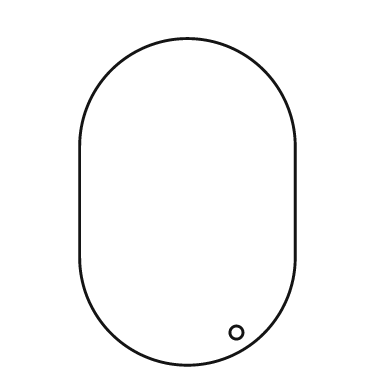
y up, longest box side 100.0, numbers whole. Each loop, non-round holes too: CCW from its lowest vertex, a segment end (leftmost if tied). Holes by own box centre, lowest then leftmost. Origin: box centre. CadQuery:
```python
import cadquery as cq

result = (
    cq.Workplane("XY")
    .moveTo(-33.0, -17.0)
    .threePointArc((0.0, -50.0), (33.0, -17.0))
    .lineTo(33.0, 17.0)
    .threePointArc((0.0, 50.0), (-33.0, 17.0))
    .close()
    .moveTo(15.0, -40.0)
    .circle(2.0)
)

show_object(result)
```